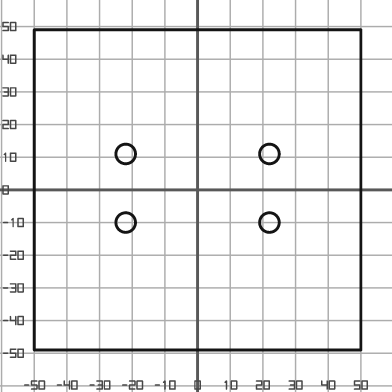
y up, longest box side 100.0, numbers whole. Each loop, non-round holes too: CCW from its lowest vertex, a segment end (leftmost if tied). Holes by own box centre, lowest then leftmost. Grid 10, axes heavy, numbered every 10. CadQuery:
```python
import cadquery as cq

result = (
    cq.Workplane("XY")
    .moveTo(-50.0, -49.0)
    .lineTo(50.0, -49.0)
    .lineTo(50.0, 49.0)
    .lineTo(-50.0, 49.0)
    .close()
    .moveTo(-22.0, -10.0)
    .circle(3.0)
    .moveTo(22.0, -10.0)
    .circle(3.0)
    .moveTo(-22.0, 11.0)
    .circle(3.0)
    .moveTo(22.0, 11.0)
    .circle(3.0)
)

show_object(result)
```